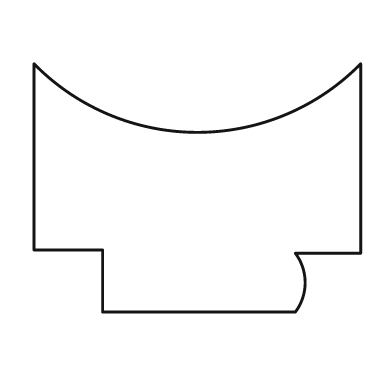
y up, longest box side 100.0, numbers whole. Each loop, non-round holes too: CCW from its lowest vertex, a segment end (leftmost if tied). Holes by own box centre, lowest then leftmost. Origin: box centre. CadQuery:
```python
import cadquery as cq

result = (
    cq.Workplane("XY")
    .moveTo(-29.0, -38.0)
    .lineTo(30.0, -38.0)
    .threePointArc((33.0, -29.0), (30.0, -20.0))
    .lineTo(50.0, -20.0)
    .lineTo(50.0, 38.0)
    .threePointArc((0.0, 17.0), (-50.0, 38.0))
    .lineTo(-50.0, -19.0)
    .lineTo(-29.0, -19.0)
    .close()
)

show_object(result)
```